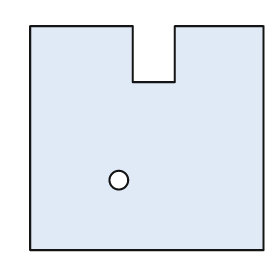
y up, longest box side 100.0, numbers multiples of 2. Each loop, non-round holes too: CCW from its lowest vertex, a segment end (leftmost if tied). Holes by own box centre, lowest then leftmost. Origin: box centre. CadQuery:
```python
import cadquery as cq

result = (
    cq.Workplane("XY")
    .moveTo(-50.0, -48.0)
    .lineTo(50.0, -48.0)
    .lineTo(50.0, 48.0)
    .lineTo(12.0, 48.0)
    .lineTo(12.0, 24.0)
    .lineTo(-6.0, 24.0)
    .lineTo(-6.0, 48.0)
    .lineTo(-50.0, 48.0)
    .close()
    .moveTo(-12.0, -18.0)
    .circle(4.0)
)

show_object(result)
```